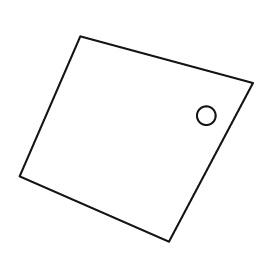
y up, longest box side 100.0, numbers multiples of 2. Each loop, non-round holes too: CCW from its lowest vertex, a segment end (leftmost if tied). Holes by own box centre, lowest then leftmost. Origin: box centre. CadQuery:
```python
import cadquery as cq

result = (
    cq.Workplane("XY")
    .moveTo(14.0, -44.0)
    .lineTo(50.0, 24.0)
    .lineTo(-24.0, 44.0)
    .lineTo(-50.0, -16.0)
    .close()
    .moveTo(30.0, 10.0)
    .circle(4.0)
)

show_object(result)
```